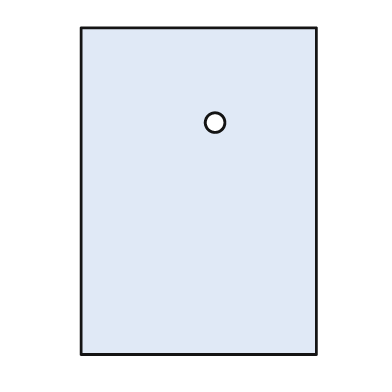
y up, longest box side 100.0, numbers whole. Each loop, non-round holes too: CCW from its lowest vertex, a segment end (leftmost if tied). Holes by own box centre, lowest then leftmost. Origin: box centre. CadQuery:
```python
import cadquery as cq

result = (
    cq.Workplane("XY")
    .moveTo(-36.0, -50.0)
    .lineTo(36.0, -50.0)
    .lineTo(36.0, 50.0)
    .lineTo(-36.0, 50.0)
    .close()
    .moveTo(5.0, 21.0)
    .circle(3.0)
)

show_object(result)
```